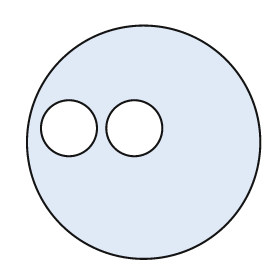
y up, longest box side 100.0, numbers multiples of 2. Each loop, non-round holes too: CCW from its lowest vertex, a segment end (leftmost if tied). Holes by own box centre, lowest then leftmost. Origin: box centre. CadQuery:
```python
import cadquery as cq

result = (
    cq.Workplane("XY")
    .moveTo(0.0, 0.0)
    .circle(50.0)
    .moveTo(-32.0, 6.0)
    .circle(12.0)
    .moveTo(-4.0, 6.0)
    .circle(12.0)
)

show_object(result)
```